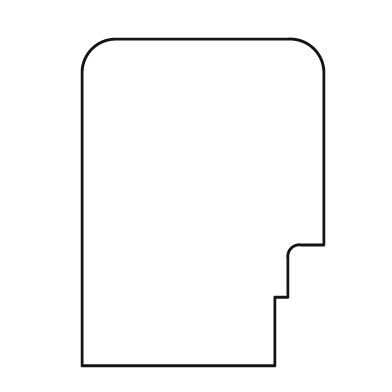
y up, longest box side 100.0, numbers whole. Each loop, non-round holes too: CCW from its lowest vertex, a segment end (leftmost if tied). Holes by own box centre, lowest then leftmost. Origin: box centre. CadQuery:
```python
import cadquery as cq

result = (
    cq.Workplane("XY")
    .moveTo(-37.0, -50.0)
    .lineTo(22.0, -50.0)
    .lineTo(22.0, -29.0)
    .lineTo(26.0, -29.0)
    .lineTo(26.0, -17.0)
    .threePointArc((27.0, -14.0), (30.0, -13.0))
    .lineTo(37.0, -13.0)
    .lineTo(37.0, 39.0)
    .threePointArc((34.0, 47.0), (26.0, 50.0))
    .lineTo(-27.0, 50.0)
    .threePointArc((-34.0, 47.0), (-37.0, 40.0))
    .close()
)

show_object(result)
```